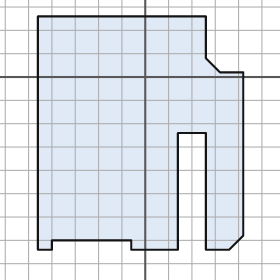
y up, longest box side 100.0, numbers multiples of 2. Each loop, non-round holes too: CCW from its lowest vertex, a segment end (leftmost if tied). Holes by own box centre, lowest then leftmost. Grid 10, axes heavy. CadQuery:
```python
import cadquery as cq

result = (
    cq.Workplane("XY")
    .moveTo(-46.0, -74.0)
    .lineTo(-40.0, -74.0)
    .lineTo(-40.0, -70.0)
    .lineTo(-6.0, -70.0)
    .lineTo(-6.0, -74.0)
    .lineTo(14.0, -74.0)
    .lineTo(14.0, -24.0)
    .lineTo(26.0, -24.0)
    .lineTo(26.0, -74.0)
    .lineTo(36.0, -74.0)
    .lineTo(42.0, -68.0)
    .lineTo(42.0, 2.0)
    .lineTo(32.0, 2.0)
    .lineTo(26.0, 8.0)
    .lineTo(26.0, 26.0)
    .lineTo(-46.0, 26.0)
    .close()
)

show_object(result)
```